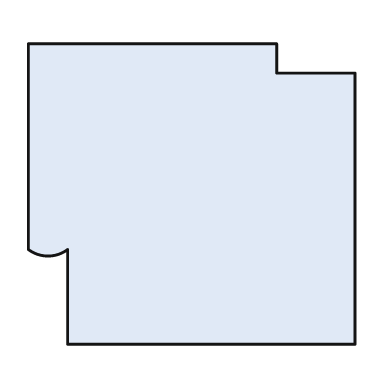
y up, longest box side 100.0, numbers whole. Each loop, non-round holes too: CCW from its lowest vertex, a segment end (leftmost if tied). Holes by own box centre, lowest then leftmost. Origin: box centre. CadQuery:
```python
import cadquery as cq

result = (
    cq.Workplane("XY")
    .moveTo(-38.0, -46.0)
    .lineTo(50.0, -46.0)
    .lineTo(50.0, 37.0)
    .lineTo(26.0, 37.0)
    .lineTo(26.0, 46.0)
    .lineTo(-50.0, 46.0)
    .lineTo(-50.0, -17.0)
    .threePointArc((-44.0, -19.0), (-38.0, -17.0))
    .close()
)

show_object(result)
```